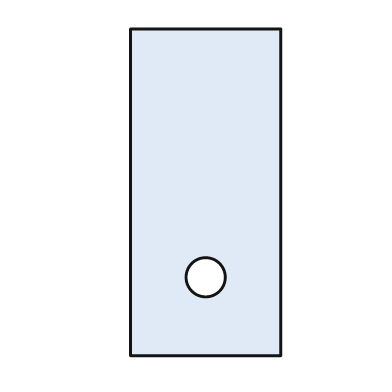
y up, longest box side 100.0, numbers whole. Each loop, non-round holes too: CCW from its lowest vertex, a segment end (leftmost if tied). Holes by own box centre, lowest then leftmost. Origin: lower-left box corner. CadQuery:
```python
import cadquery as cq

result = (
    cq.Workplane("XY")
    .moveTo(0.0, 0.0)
    .lineTo(46.0, 0.0)
    .lineTo(46.0, 100.0)
    .lineTo(0.0, 100.0)
    .close()
    .moveTo(23.0, 24.0)
    .circle(6.0)
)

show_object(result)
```